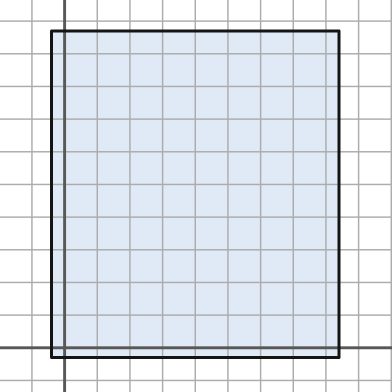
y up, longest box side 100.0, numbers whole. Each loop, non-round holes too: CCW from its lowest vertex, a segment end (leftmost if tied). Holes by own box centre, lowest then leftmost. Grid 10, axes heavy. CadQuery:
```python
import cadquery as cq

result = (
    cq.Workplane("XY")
    .moveTo(-4.0, -3.0)
    .lineTo(84.0, -3.0)
    .lineTo(84.0, 97.0)
    .lineTo(-4.0, 97.0)
    .close()
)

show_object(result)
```